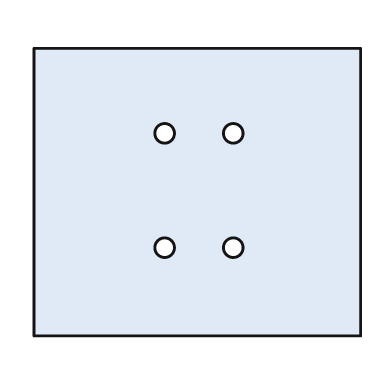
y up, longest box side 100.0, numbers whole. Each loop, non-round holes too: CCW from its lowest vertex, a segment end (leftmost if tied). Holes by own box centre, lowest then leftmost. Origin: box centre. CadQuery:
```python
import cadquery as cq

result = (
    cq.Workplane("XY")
    .moveTo(-50.0, -44.0)
    .lineTo(50.0, -44.0)
    .lineTo(50.0, 44.0)
    .lineTo(-50.0, 44.0)
    .close()
    .moveTo(-10.0, -17.0)
    .circle(3.0)
    .moveTo(11.0, -17.0)
    .circle(3.0)
    .moveTo(-10.0, 18.0)
    .circle(3.0)
    .moveTo(11.0, 18.0)
    .circle(3.0)
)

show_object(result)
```